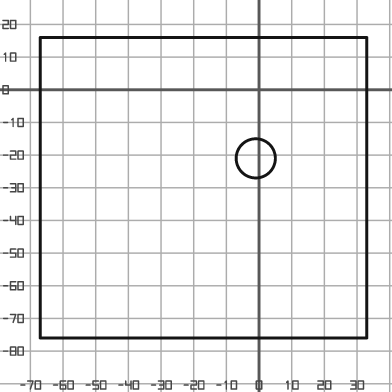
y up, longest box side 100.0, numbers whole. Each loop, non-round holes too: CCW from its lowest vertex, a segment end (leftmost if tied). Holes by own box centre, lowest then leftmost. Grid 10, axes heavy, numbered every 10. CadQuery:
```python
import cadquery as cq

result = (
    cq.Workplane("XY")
    .moveTo(-67.0, -76.0)
    .lineTo(33.0, -76.0)
    .lineTo(33.0, 16.0)
    .lineTo(-67.0, 16.0)
    .close()
    .moveTo(-1.0, -21.0)
    .circle(6.0)
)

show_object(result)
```